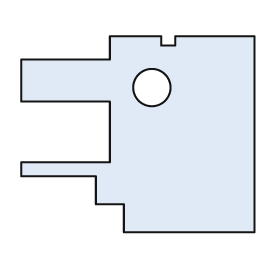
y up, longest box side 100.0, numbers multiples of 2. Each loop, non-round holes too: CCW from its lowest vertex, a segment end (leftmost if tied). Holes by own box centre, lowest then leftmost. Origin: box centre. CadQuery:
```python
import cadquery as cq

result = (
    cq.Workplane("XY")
    .moveTo(-6.0, -42.0)
    .lineTo(50.0, -42.0)
    .lineTo(50.0, 42.0)
    .lineTo(16.0, 42.0)
    .lineTo(16.0, 38.0)
    .lineTo(10.0, 38.0)
    .lineTo(10.0, 42.0)
    .lineTo(-12.0, 42.0)
    .lineTo(-12.0, 32.0)
    .lineTo(-50.0, 32.0)
    .lineTo(-50.0, 14.0)
    .lineTo(-12.0, 14.0)
    .lineTo(-12.0, -12.0)
    .lineTo(-50.0, -12.0)
    .lineTo(-50.0, -18.0)
    .lineTo(-18.0, -18.0)
    .lineTo(-18.0, -30.0)
    .lineTo(-6.0, -30.0)
    .close()
    .moveTo(6.0, 20.0)
    .circle(8.0)
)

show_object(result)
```